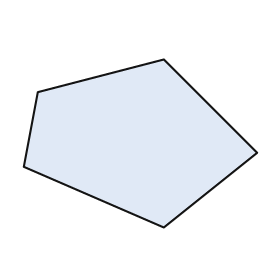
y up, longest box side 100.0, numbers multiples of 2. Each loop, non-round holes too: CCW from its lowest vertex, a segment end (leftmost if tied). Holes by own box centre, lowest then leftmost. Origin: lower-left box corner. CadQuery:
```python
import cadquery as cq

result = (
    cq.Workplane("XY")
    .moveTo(60.0, 0.0)
    .lineTo(100.0, 32.0)
    .lineTo(60.0, 72.0)
    .lineTo(6.0, 58.0)
    .lineTo(0.0, 26.0)
    .close()
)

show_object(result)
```